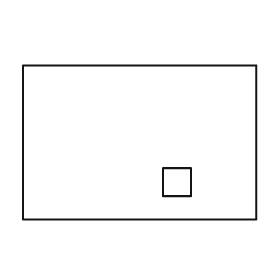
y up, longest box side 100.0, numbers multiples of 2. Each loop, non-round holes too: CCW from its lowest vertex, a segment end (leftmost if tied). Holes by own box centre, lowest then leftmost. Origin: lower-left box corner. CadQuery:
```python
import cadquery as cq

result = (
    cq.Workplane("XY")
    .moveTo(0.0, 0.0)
    .lineTo(100.0, 0.0)
    .lineTo(100.0, 66.0)
    .lineTo(0.0, 66.0)
    .close()
    .moveTo(60.0, 10.0)
    .lineTo(72.0, 10.0)
    .lineTo(72.0, 22.0)
    .lineTo(60.0, 22.0)
    .close()
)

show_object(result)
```